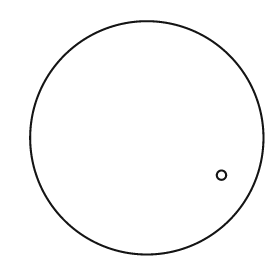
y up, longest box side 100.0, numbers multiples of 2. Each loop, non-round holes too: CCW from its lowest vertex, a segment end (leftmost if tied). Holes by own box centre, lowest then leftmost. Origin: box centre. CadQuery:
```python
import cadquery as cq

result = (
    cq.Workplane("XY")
    .moveTo(0.0, 0.0)
    .circle(50.0)
    .moveTo(32.0, -16.0)
    .circle(2.0)
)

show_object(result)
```